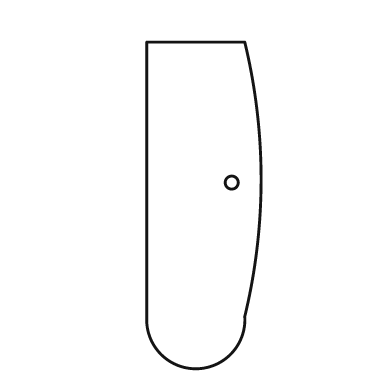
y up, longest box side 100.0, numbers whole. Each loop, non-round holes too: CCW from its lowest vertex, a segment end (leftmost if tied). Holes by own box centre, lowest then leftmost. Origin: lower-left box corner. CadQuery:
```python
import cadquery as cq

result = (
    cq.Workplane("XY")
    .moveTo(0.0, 16.0)
    .threePointArc((15.0, 0.0), (30.0, 16.0))
    .threePointArc((35.0, 58.0), (30.0, 100.0))
    .lineTo(0.0, 100.0)
    .close()
    .moveTo(26.0, 57.0)
    .circle(2.0)
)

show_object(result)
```